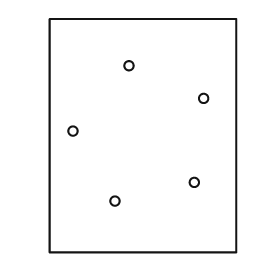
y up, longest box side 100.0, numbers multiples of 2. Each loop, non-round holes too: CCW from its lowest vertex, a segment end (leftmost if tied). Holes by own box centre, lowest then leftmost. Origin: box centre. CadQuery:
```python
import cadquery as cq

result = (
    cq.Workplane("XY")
    .moveTo(-40.0, -50.0)
    .lineTo(40.0, -50.0)
    .lineTo(40.0, 50.0)
    .lineTo(-40.0, 50.0)
    .close()
    .moveTo(-12.0, -28.0)
    .circle(2.0)
    .moveTo(22.0, -20.0)
    .circle(2.0)
    .moveTo(-30.0, 2.0)
    .circle(2.0)
    .moveTo(26.0, 16.0)
    .circle(2.0)
    .moveTo(-6.0, 30.0)
    .circle(2.0)
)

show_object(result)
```